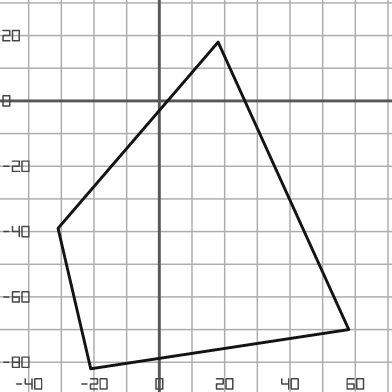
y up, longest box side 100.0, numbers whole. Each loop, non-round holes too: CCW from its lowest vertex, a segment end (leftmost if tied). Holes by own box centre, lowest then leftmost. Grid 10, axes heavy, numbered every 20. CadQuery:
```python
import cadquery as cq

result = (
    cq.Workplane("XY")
    .moveTo(-21.0, -82.0)
    .lineTo(58.0, -70.0)
    .lineTo(18.0, 18.0)
    .lineTo(-31.0, -39.0)
    .close()
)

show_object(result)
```